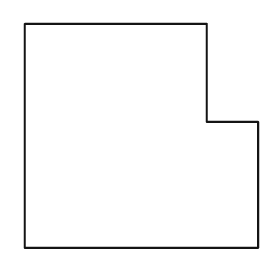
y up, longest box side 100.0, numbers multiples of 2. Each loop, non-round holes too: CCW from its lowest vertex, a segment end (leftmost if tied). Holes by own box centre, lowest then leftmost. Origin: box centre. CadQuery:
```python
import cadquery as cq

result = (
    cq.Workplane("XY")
    .moveTo(-50.0, -48.0)
    .lineTo(50.0, -48.0)
    .lineTo(50.0, 6.0)
    .lineTo(28.0, 6.0)
    .lineTo(28.0, 48.0)
    .lineTo(-50.0, 48.0)
    .close()
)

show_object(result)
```